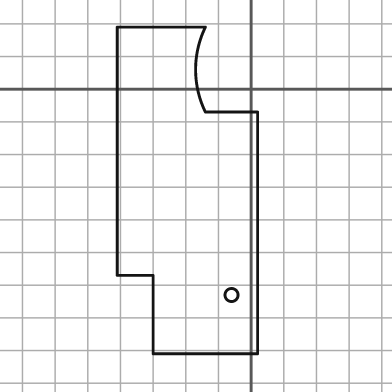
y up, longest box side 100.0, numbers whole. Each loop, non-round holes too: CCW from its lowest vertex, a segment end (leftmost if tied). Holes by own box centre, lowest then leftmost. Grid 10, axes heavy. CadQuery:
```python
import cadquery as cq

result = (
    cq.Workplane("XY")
    .moveTo(-30.0, -81.0)
    .lineTo(2.0, -81.0)
    .lineTo(2.0, -7.0)
    .lineTo(-14.0, -7.0)
    .threePointArc((-17.0, 6.0), (-14.0, 19.0))
    .lineTo(-41.0, 19.0)
    .lineTo(-41.0, -57.0)
    .lineTo(-30.0, -57.0)
    .close()
    .moveTo(-6.0, -63.0)
    .circle(2.0)
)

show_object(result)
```